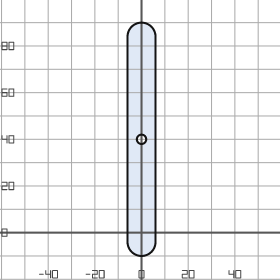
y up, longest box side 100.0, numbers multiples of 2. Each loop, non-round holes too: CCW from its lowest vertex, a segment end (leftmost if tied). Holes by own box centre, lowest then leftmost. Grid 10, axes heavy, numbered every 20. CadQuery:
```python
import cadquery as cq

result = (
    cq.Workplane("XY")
    .moveTo(-6.0, -4.0)
    .threePointArc((0.0, -10.0), (6.0, -4.0))
    .lineTo(6.0, 84.0)
    .threePointArc((0.0, 90.0), (-6.0, 84.0))
    .close()
    .moveTo(0.0, 40.0)
    .circle(2.0)
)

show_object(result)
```